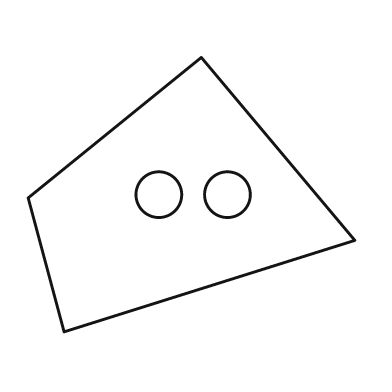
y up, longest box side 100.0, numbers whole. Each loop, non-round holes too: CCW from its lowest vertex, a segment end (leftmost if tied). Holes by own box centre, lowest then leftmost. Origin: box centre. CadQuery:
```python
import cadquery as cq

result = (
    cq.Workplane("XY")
    .moveTo(-39.0, -42.0)
    .lineTo(50.0, -14.0)
    .lineTo(3.0, 42.0)
    .lineTo(-50.0, -1.0)
    .close()
    .moveTo(-10.0, 0.0)
    .circle(7.0)
    .moveTo(11.0, 0.0)
    .circle(7.0)
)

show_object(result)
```